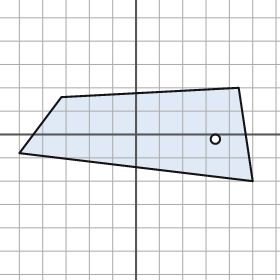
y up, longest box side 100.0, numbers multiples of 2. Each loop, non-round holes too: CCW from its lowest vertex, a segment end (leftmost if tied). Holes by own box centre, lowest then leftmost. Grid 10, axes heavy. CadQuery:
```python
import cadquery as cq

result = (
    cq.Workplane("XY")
    .moveTo(50.0, -20.0)
    .lineTo(44.0, 20.0)
    .lineTo(-32.0, 16.0)
    .lineTo(-50.0, -8.0)
    .close()
    .moveTo(34.0, -2.0)
    .circle(2.0)
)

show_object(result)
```